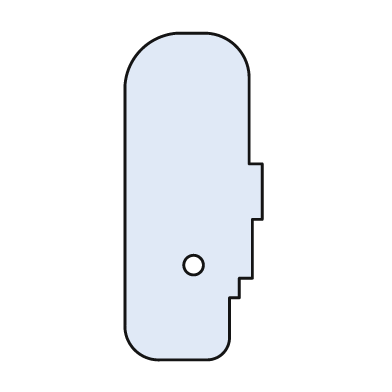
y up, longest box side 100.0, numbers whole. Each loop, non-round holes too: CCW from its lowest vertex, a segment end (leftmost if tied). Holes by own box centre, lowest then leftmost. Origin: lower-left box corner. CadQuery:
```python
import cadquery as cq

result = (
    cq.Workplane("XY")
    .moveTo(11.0, 0.0)
    .lineTo(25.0, 0.0)
    .threePointArc((30.0, 2.0), (32.0, 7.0))
    .lineTo(32.0, 19.0)
    .lineTo(35.0, 19.0)
    .lineTo(35.0, 25.0)
    .lineTo(39.0, 25.0)
    .lineTo(39.0, 43.0)
    .lineTo(42.0, 43.0)
    .lineTo(42.0, 60.0)
    .lineTo(38.0, 60.0)
    .lineTo(38.0, 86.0)
    .threePointArc((34.0, 96.0), (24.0, 100.0))
    .lineTo(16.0, 100.0)
    .threePointArc((5.0, 95.0), (0.0, 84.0))
    .lineTo(0.0, 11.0)
    .threePointArc((3.0, 3.0), (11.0, 0.0))
    .close()
    .moveTo(21.0, 29.0)
    .circle(3.0)
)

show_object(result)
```